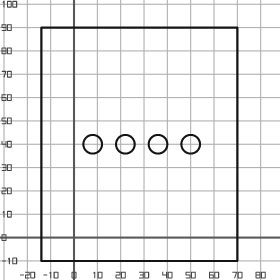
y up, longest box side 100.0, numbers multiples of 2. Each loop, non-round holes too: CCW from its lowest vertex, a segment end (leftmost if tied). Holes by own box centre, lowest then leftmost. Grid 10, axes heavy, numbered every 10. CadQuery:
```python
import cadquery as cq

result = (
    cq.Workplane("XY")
    .moveTo(-14.0, -10.0)
    .lineTo(70.0, -10.0)
    .lineTo(70.0, 90.0)
    .lineTo(-14.0, 90.0)
    .close()
    .moveTo(8.0, 40.0)
    .circle(4.0)
    .moveTo(22.0, 40.0)
    .circle(4.0)
    .moveTo(36.0, 40.0)
    .circle(4.0)
    .moveTo(50.0, 40.0)
    .circle(4.0)
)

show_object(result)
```